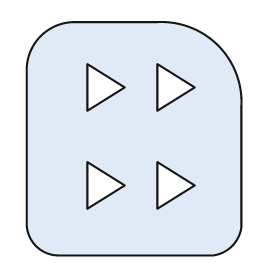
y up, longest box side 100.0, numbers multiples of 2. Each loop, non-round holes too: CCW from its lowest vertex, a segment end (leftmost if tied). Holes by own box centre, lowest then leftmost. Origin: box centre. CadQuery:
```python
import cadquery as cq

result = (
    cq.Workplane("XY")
    .moveTo(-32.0, -50.0)
    .lineTo(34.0, -50.0)
    .threePointArc((42.0, -46.0), (46.0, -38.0))
    .lineTo(46.0, 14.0)
    .threePointArc((36.0, 40.0), (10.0, 50.0))
    .lineTo(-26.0, 50.0)
    .threePointArc((-40.0, 44.0), (-46.0, 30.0))
    .lineTo(-46.0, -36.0)
    .threePointArc((-42.0, -46.0), (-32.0, -50.0))
    .close()
    .moveTo(-20.0, -30.0)
    .lineTo(-4.0, -20.0)
    .lineTo(-20.0, -10.0)
    .close()
    .moveTo(10.0, -30.0)
    .lineTo(26.0, -20.0)
    .lineTo(10.0, -10.0)
    .close()
    .moveTo(-20.0, 12.0)
    .lineTo(-4.0, 22.0)
    .lineTo(-20.0, 32.0)
    .close()
    .moveTo(10.0, 12.0)
    .lineTo(26.0, 22.0)
    .lineTo(10.0, 32.0)
    .close()
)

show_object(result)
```